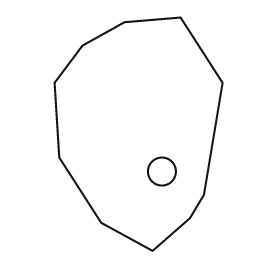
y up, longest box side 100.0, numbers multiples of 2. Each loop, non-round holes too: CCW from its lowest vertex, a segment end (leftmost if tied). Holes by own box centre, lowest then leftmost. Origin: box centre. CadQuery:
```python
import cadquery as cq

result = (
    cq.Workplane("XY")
    .moveTo(6.0, -50.0)
    .lineTo(22.0, -36.0)
    .lineTo(28.0, -26.0)
    .lineTo(36.0, 22.0)
    .lineTo(18.0, 50.0)
    .lineTo(-6.0, 48.0)
    .lineTo(-24.0, 38.0)
    .lineTo(-36.0, 22.0)
    .lineTo(-34.0, -10.0)
    .lineTo(-16.0, -38.0)
    .close()
    .moveTo(10.0, -16.0)
    .circle(6.0)
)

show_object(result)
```